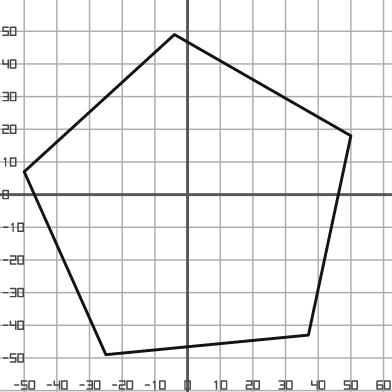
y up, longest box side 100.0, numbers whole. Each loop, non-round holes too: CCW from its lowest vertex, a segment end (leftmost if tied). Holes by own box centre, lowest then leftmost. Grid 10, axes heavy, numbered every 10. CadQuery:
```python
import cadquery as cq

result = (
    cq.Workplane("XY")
    .moveTo(-25.0, -49.0)
    .lineTo(37.0, -43.0)
    .lineTo(50.0, 18.0)
    .lineTo(-4.0, 49.0)
    .lineTo(-50.0, 7.0)
    .close()
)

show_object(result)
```